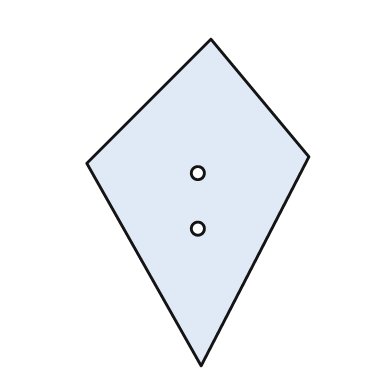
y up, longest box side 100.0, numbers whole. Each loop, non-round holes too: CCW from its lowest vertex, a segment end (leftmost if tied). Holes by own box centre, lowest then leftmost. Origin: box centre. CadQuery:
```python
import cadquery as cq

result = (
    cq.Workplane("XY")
    .moveTo(1.0, -50.0)
    .lineTo(34.0, 14.0)
    .lineTo(4.0, 50.0)
    .lineTo(-34.0, 12.0)
    .close()
    .moveTo(0.0, -8.0)
    .circle(2.0)
    .moveTo(0.0, 9.0)
    .circle(2.0)
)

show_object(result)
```